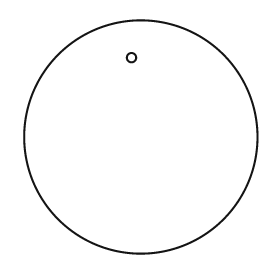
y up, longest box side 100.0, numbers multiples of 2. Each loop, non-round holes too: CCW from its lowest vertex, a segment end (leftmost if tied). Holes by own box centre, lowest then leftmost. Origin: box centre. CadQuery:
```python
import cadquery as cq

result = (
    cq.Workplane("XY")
    .moveTo(0.0, 0.0)
    .circle(50.0)
    .moveTo(-4.0, 34.0)
    .circle(2.0)
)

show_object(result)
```